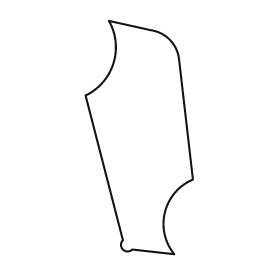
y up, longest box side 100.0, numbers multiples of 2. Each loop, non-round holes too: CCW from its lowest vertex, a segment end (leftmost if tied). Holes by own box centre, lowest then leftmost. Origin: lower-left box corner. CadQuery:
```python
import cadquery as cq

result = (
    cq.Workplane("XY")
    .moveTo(38.0, 0.0)
    .threePointArc((34.0, 18.0), (46.0, 32.0))
    .lineTo(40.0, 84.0)
    .threePointArc((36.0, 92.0), (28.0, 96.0))
    .lineTo(10.0, 100.0)
    .threePointArc((12.0, 82.0), (0.0, 68.0))
    .lineTo(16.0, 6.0)
    .threePointArc((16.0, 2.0), (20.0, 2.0))
    .close()
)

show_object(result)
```